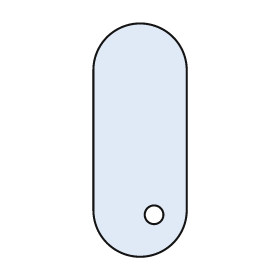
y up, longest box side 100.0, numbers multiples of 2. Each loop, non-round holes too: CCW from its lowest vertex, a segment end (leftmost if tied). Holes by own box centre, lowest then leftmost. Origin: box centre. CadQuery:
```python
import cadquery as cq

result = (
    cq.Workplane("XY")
    .moveTo(-20.0, -30.0)
    .threePointArc((0.0, -50.0), (20.0, -30.0))
    .lineTo(20.0, 30.0)
    .threePointArc((0.0, 50.0), (-20.0, 30.0))
    .close()
    .moveTo(6.0, -32.0)
    .circle(4.0)
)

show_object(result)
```